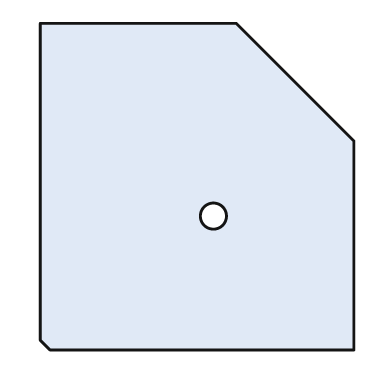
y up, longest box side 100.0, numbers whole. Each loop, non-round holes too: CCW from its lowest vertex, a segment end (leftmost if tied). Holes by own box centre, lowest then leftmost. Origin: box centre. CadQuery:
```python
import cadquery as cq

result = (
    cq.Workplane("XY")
    .moveTo(-45.0, -50.0)
    .lineTo(48.0, -50.0)
    .lineTo(48.0, 14.0)
    .lineTo(12.0, 50.0)
    .lineTo(-48.0, 50.0)
    .lineTo(-48.0, -47.0)
    .close()
    .moveTo(5.0, -9.0)
    .circle(4.0)
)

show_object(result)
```